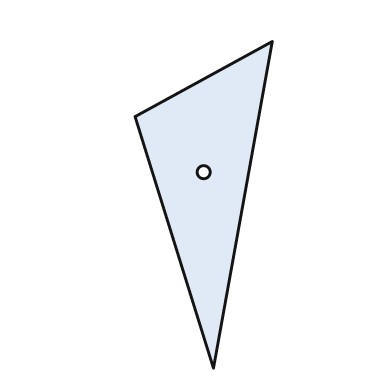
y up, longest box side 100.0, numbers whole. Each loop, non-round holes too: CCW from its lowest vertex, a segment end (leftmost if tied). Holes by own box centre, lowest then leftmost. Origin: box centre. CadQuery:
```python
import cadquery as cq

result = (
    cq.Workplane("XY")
    .moveTo(3.0, -50.0)
    .lineTo(21.0, 50.0)
    .lineTo(-21.0, 27.0)
    .close()
    .moveTo(0.0, 10.0)
    .circle(2.0)
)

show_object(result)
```